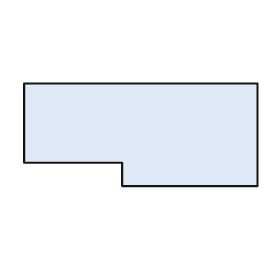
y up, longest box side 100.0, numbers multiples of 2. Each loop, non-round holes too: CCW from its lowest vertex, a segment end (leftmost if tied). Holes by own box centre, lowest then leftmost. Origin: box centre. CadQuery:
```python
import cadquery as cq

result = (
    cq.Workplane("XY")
    .moveTo(-8.0, -22.0)
    .lineTo(50.0, -22.0)
    .lineTo(50.0, 22.0)
    .lineTo(-50.0, 22.0)
    .lineTo(-50.0, -12.0)
    .lineTo(-8.0, -12.0)
    .close()
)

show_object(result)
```